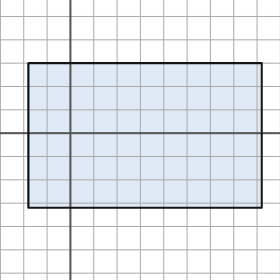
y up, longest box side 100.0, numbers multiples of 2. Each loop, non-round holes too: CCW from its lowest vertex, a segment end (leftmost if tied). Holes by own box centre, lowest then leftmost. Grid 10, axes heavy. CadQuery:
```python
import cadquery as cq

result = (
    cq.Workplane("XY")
    .moveTo(-18.0, -32.0)
    .lineTo(82.0, -32.0)
    .lineTo(82.0, 30.0)
    .lineTo(-18.0, 30.0)
    .close()
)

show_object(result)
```